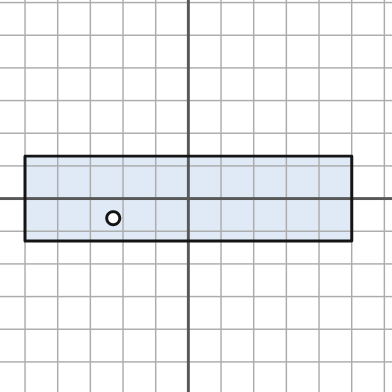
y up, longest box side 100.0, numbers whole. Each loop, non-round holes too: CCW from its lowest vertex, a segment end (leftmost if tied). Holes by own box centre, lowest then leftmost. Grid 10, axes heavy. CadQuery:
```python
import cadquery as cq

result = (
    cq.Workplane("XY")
    .moveTo(-50.0, -13.0)
    .lineTo(50.0, -13.0)
    .lineTo(50.0, 13.0)
    .lineTo(-50.0, 13.0)
    .close()
    .moveTo(-23.0, -6.0)
    .circle(2.0)
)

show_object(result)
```